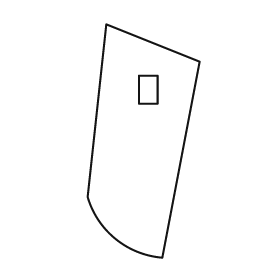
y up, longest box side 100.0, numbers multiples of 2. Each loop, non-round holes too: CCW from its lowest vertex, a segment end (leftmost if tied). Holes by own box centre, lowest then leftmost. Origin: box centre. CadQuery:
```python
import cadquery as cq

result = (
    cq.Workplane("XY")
    .moveTo(8.0, -50.0)
    .lineTo(24.0, 34.0)
    .lineTo(-16.0, 50.0)
    .lineTo(-24.0, -24.0)
    .threePointArc((-12.0, -42.0), (8.0, -50.0))
    .close()
    .moveTo(-2.0, 16.0)
    .lineTo(6.0, 16.0)
    .lineTo(6.0, 28.0)
    .lineTo(-2.0, 28.0)
    .close()
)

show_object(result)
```